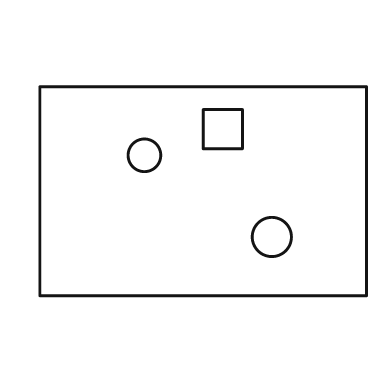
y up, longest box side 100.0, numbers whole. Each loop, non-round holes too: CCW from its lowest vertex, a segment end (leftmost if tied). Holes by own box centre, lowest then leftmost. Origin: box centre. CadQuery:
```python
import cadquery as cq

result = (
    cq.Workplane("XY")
    .moveTo(-50.0, -32.0)
    .lineTo(50.0, -32.0)
    .lineTo(50.0, 32.0)
    .lineTo(-50.0, 32.0)
    .close()
    .moveTo(21.0, -14.0)
    .circle(6.0)
    .moveTo(-18.0, 11.0)
    .circle(5.0)
    .moveTo(0.0, 13.0)
    .lineTo(12.0, 13.0)
    .lineTo(12.0, 25.0)
    .lineTo(0.0, 25.0)
    .close()
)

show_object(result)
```